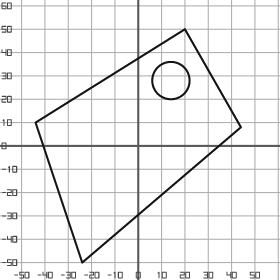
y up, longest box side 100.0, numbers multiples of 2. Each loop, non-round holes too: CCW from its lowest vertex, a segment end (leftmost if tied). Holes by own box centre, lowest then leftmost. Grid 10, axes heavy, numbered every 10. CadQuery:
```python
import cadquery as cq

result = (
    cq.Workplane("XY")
    .moveTo(-24.0, -50.0)
    .lineTo(44.0, 8.0)
    .lineTo(20.0, 50.0)
    .lineTo(-44.0, 10.0)
    .close()
    .moveTo(14.0, 28.0)
    .circle(8.0)
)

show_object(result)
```